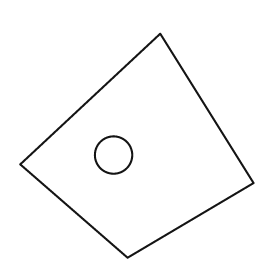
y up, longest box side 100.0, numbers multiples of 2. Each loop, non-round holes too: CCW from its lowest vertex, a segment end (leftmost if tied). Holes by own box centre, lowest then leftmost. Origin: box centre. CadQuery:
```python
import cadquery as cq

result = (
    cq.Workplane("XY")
    .moveTo(-4.0, -48.0)
    .lineTo(50.0, -16.0)
    .lineTo(10.0, 48.0)
    .lineTo(-50.0, -8.0)
    .close()
    .moveTo(-10.0, -4.0)
    .circle(8.0)
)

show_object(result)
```